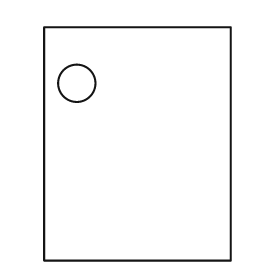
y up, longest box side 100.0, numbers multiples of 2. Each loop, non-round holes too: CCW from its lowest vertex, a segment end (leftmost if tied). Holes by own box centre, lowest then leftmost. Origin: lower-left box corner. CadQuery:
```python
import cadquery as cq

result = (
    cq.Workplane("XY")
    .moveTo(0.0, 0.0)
    .lineTo(80.0, 0.0)
    .lineTo(80.0, 100.0)
    .lineTo(0.0, 100.0)
    .close()
    .moveTo(14.0, 76.0)
    .circle(8.0)
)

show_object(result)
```